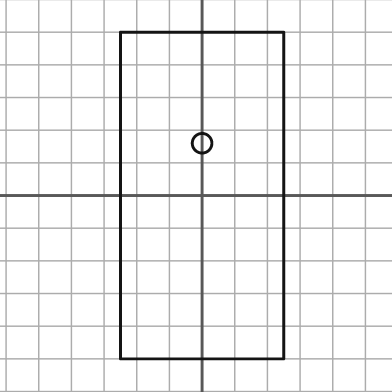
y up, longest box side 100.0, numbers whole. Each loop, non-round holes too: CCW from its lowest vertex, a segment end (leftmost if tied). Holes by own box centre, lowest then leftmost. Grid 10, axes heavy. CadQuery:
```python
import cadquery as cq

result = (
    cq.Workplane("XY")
    .moveTo(-25.0, -50.0)
    .lineTo(25.0, -50.0)
    .lineTo(25.0, 50.0)
    .lineTo(-25.0, 50.0)
    .close()
    .moveTo(0.0, 16.0)
    .circle(3.0)
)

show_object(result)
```